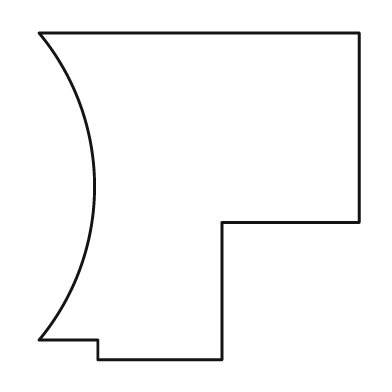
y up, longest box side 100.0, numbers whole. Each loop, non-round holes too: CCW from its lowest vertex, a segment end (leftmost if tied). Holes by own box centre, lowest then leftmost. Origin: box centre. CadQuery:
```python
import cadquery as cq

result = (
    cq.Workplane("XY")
    .moveTo(-31.0, -50.0)
    .lineTo(7.0, -50.0)
    .lineTo(7.0, -8.0)
    .lineTo(49.0, -8.0)
    .lineTo(49.0, 50.0)
    .lineTo(-49.0, 50.0)
    .threePointArc((-32.0, 3.0), (-49.0, -44.0))
    .lineTo(-31.0, -44.0)
    .close()
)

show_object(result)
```